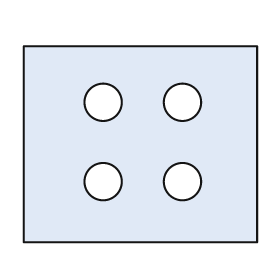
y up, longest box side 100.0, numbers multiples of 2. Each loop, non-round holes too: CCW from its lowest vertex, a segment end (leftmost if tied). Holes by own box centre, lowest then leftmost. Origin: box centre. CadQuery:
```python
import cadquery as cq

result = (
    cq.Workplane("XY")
    .moveTo(-50.0, -42.0)
    .lineTo(50.0, -42.0)
    .lineTo(50.0, 42.0)
    .lineTo(-50.0, 42.0)
    .close()
    .moveTo(-16.0, -16.0)
    .circle(8.0)
    .moveTo(18.0, -16.0)
    .circle(8.0)
    .moveTo(-16.0, 18.0)
    .circle(8.0)
    .moveTo(18.0, 18.0)
    .circle(8.0)
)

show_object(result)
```